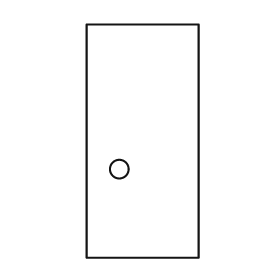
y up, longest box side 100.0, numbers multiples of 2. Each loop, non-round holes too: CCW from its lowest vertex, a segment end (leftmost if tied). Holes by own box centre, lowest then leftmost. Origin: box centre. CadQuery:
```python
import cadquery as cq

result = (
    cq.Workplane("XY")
    .moveTo(-24.0, -50.0)
    .lineTo(24.0, -50.0)
    .lineTo(24.0, 50.0)
    .lineTo(-24.0, 50.0)
    .close()
    .moveTo(-10.0, -12.0)
    .circle(4.0)
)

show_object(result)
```